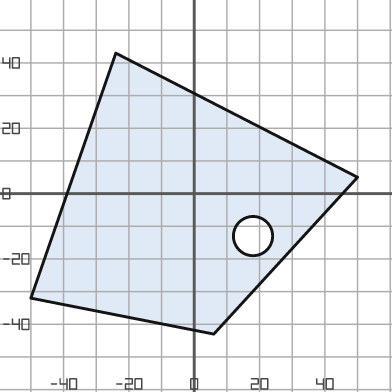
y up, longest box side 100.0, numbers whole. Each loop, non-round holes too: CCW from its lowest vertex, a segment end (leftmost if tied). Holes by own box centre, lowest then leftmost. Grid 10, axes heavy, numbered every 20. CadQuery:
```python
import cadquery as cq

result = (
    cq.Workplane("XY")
    .moveTo(6.0, -43.0)
    .lineTo(50.0, 5.0)
    .lineTo(-24.0, 43.0)
    .lineTo(-50.0, -32.0)
    .close()
    .moveTo(18.0, -13.0)
    .circle(6.0)
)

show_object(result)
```